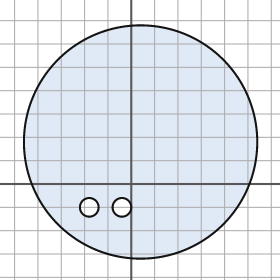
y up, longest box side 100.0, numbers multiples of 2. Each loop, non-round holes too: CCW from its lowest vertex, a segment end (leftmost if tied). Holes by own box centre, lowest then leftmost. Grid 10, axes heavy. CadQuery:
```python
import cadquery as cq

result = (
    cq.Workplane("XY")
    .moveTo(4.0, 18.0)
    .circle(50.0)
    .moveTo(-18.0, -10.0)
    .circle(4.0)
    .moveTo(-4.0, -10.0)
    .circle(4.0)
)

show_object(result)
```